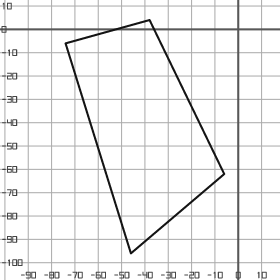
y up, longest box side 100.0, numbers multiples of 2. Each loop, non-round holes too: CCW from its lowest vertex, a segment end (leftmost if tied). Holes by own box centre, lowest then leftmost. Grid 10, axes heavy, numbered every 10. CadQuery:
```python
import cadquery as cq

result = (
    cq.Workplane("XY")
    .moveTo(-46.0, -96.0)
    .lineTo(-6.0, -62.0)
    .lineTo(-38.0, 4.0)
    .lineTo(-74.0, -6.0)
    .close()
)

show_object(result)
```